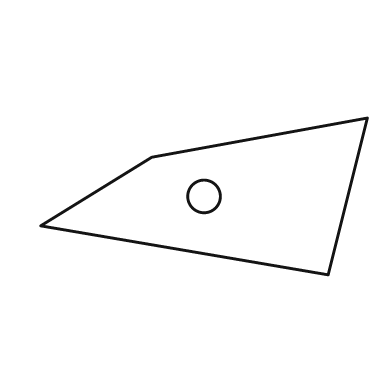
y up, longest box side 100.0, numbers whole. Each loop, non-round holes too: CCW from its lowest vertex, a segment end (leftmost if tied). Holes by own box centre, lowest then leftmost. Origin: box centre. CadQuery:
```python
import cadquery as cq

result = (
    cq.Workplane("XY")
    .moveTo(38.0, -24.0)
    .lineTo(50.0, 24.0)
    .lineTo(-16.0, 12.0)
    .lineTo(-50.0, -9.0)
    .close()
    .moveTo(0.0, 0.0)
    .circle(5.0)
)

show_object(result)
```